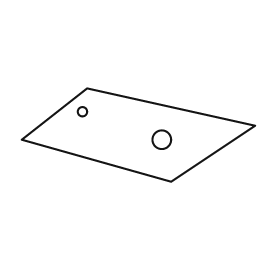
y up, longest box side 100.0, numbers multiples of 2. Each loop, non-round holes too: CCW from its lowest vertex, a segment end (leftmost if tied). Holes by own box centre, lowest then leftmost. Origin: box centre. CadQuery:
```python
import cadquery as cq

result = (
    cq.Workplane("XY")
    .moveTo(14.0, -20.0)
    .lineTo(50.0, 4.0)
    .lineTo(-22.0, 20.0)
    .lineTo(-50.0, -2.0)
    .close()
    .moveTo(10.0, -2.0)
    .circle(4.0)
    .moveTo(-24.0, 10.0)
    .circle(2.0)
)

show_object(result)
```